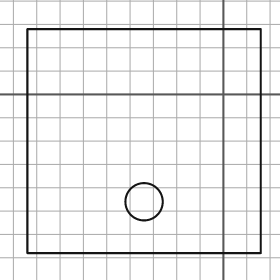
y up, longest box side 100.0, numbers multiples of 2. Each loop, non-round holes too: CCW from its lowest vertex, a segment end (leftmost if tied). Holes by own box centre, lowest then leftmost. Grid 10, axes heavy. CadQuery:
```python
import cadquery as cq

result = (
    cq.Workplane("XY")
    .moveTo(-84.0, -68.0)
    .lineTo(16.0, -68.0)
    .lineTo(16.0, 28.0)
    .lineTo(-84.0, 28.0)
    .close()
    .moveTo(-34.0, -46.0)
    .circle(8.0)
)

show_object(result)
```